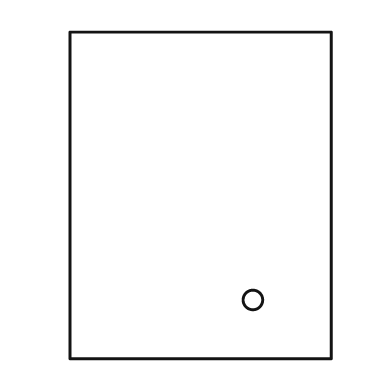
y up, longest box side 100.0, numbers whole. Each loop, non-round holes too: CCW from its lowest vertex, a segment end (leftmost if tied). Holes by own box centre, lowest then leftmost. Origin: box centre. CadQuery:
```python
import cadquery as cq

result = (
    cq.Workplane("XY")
    .moveTo(-40.0, -50.0)
    .lineTo(40.0, -50.0)
    .lineTo(40.0, 50.0)
    .lineTo(-40.0, 50.0)
    .close()
    .moveTo(16.0, -32.0)
    .circle(3.0)
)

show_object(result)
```